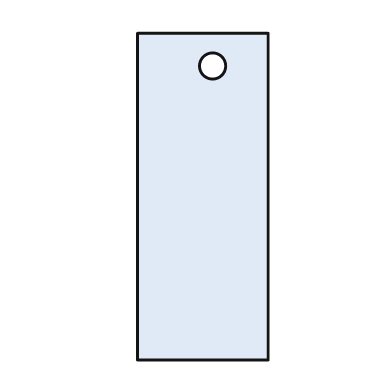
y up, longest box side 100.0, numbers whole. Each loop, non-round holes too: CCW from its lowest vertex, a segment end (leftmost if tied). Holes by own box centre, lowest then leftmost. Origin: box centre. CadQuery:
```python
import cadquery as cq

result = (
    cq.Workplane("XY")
    .moveTo(-20.0, -50.0)
    .lineTo(20.0, -50.0)
    .lineTo(20.0, 50.0)
    .lineTo(-20.0, 50.0)
    .close()
    .moveTo(3.0, 40.0)
    .circle(4.0)
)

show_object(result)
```